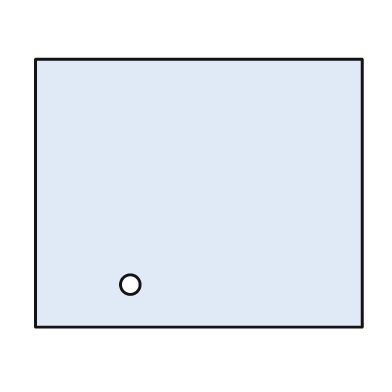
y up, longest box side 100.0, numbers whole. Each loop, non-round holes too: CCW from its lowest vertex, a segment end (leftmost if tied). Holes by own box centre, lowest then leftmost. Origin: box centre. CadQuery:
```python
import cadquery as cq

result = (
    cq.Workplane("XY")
    .moveTo(-50.0, -41.0)
    .lineTo(50.0, -41.0)
    .lineTo(50.0, 41.0)
    .lineTo(-50.0, 41.0)
    .close()
    .moveTo(-21.0, -28.0)
    .circle(3.0)
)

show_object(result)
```